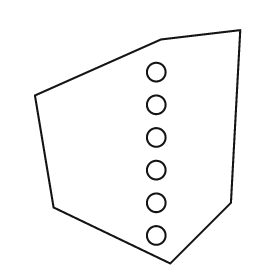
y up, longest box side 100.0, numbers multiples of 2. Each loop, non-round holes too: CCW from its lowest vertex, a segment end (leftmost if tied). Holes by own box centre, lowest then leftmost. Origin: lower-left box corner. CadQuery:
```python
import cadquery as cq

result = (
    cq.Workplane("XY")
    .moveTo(58.0, 0.0)
    .lineTo(84.0, 26.0)
    .lineTo(88.0, 100.0)
    .lineTo(54.0, 96.0)
    .lineTo(0.0, 72.0)
    .lineTo(8.0, 24.0)
    .close()
    .moveTo(52.0, 12.0)
    .circle(4.0)
    .moveTo(52.0, 26.0)
    .circle(4.0)
    .moveTo(52.0, 40.0)
    .circle(4.0)
    .moveTo(52.0, 54.0)
    .circle(4.0)
    .moveTo(52.0, 68.0)
    .circle(4.0)
    .moveTo(52.0, 82.0)
    .circle(4.0)
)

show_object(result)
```